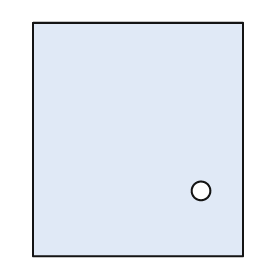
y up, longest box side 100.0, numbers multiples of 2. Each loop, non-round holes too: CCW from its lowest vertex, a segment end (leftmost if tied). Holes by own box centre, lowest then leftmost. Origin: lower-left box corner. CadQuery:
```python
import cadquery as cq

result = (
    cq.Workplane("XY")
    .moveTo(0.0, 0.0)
    .lineTo(90.0, 0.0)
    .lineTo(90.0, 100.0)
    .lineTo(0.0, 100.0)
    .close()
    .moveTo(72.0, 28.0)
    .circle(4.0)
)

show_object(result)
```